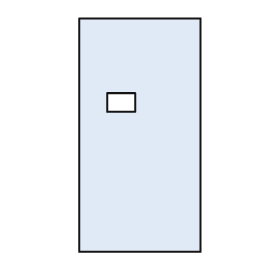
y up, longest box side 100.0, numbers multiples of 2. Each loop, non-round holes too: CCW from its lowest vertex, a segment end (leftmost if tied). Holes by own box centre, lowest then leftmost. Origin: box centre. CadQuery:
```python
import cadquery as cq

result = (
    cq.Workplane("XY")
    .moveTo(-26.0, -50.0)
    .lineTo(26.0, -50.0)
    .lineTo(26.0, 50.0)
    .lineTo(-26.0, 50.0)
    .close()
    .moveTo(-14.0, 10.0)
    .lineTo(-2.0, 10.0)
    .lineTo(-2.0, 18.0)
    .lineTo(-14.0, 18.0)
    .close()
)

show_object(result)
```